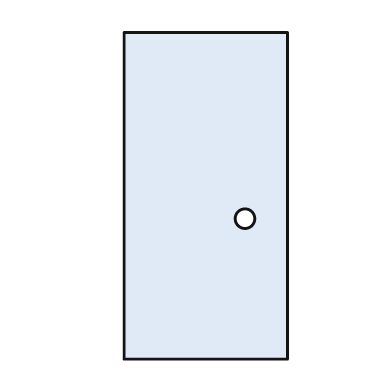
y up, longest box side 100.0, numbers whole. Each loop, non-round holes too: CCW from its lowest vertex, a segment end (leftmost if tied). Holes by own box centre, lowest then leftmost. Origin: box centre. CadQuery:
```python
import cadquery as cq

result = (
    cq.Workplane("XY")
    .moveTo(-25.0, -50.0)
    .lineTo(25.0, -50.0)
    .lineTo(25.0, 50.0)
    .lineTo(-25.0, 50.0)
    .close()
    .moveTo(12.0, -7.0)
    .circle(3.0)
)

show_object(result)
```